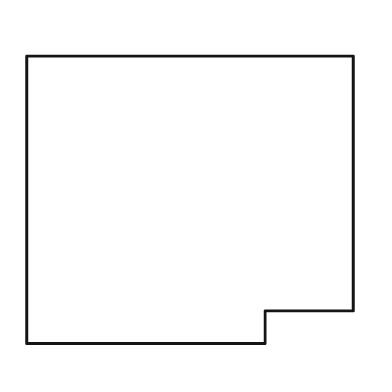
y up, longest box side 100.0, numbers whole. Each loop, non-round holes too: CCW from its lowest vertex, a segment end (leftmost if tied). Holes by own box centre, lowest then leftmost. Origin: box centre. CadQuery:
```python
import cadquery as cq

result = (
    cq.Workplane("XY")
    .moveTo(-50.0, -44.0)
    .lineTo(23.0, -44.0)
    .lineTo(23.0, -34.0)
    .lineTo(50.0, -34.0)
    .lineTo(50.0, 44.0)
    .lineTo(-50.0, 44.0)
    .close()
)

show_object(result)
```